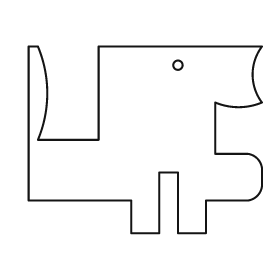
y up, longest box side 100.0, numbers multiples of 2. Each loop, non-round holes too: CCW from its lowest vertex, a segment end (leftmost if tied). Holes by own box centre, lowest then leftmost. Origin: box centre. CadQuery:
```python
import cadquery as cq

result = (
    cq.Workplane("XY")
    .moveTo(-6.0, -40.0)
    .lineTo(6.0, -40.0)
    .lineTo(6.0, -14.0)
    .lineTo(14.0, -14.0)
    .lineTo(14.0, -40.0)
    .lineTo(26.0, -40.0)
    .lineTo(26.0, -26.0)
    .lineTo(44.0, -26.0)
    .threePointArc((48.0, -24.0), (50.0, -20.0))
    .lineTo(50.0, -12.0)
    .threePointArc((48.0, -8.0), (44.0, -6.0))
    .lineTo(30.0, -6.0)
    .lineTo(30.0, 16.0)
    .threePointArc((40.0, 14.0), (50.0, 16.0))
    .threePointArc((46.0, 28.0), (50.0, 40.0))
    .lineTo(-20.0, 40.0)
    .lineTo(-20.0, 0.0)
    .lineTo(-46.0, 0.0)
    .threePointArc((-42.0, 20.0), (-46.0, 40.0))
    .lineTo(-50.0, 40.0)
    .lineTo(-50.0, -26.0)
    .lineTo(-6.0, -26.0)
    .close()
    .moveTo(14.0, 32.0)
    .circle(2.0)
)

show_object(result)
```